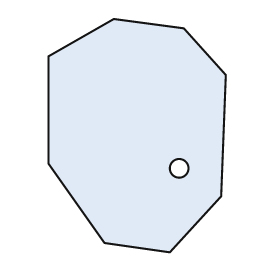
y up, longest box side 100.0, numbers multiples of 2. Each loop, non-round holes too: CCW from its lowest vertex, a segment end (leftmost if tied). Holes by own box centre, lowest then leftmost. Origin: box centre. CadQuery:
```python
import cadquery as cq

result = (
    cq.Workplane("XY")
    .moveTo(14.0, -50.0)
    .lineTo(36.0, -26.0)
    .lineTo(38.0, 26.0)
    .lineTo(20.0, 46.0)
    .lineTo(-10.0, 50.0)
    .lineTo(-38.0, 34.0)
    .lineTo(-38.0, -12.0)
    .lineTo(-14.0, -46.0)
    .close()
    .moveTo(18.0, -14.0)
    .circle(4.0)
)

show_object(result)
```